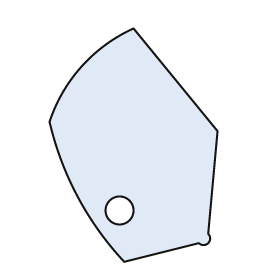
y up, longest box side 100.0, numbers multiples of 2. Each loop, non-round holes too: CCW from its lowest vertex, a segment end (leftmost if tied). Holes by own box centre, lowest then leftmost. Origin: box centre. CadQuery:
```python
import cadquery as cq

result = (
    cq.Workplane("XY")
    .moveTo(-4.0, -50.0)
    .lineTo(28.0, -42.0)
    .threePointArc((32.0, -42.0), (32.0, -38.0))
    .lineTo(36.0, 6.0)
    .lineTo(0.0, 50.0)
    .threePointArc((-22.0, 34.0), (-36.0, 10.0))
    .threePointArc((-24.0, -22.0), (-4.0, -50.0))
    .close()
    .moveTo(-6.0, -28.0)
    .circle(6.0)
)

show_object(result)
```